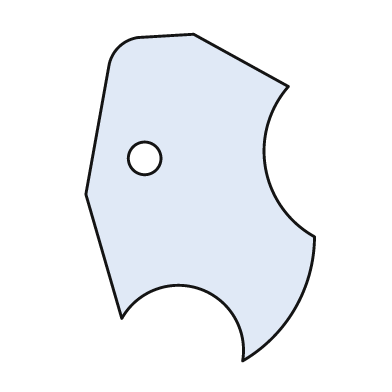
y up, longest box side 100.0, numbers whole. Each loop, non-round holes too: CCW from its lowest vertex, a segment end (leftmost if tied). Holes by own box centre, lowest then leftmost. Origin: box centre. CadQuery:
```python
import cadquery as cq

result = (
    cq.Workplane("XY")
    .moveTo(13.0, -50.0)
    .threePointArc((29.0, -34.0), (35.0, -12.0))
    .threePointArc((20.0, 9.0), (27.0, 34.0))
    .lineTo(-2.0, 50.0)
    .lineTo(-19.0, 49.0)
    .threePointArc((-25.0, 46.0), (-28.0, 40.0))
    .lineTo(-35.0, 1.0)
    .lineTo(-24.0, -37.0)
    .threePointArc((0.0, -28.0), (13.0, -50.0))
    .close()
    .moveTo(-17.0, 12.0)
    .circle(5.0)
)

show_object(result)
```